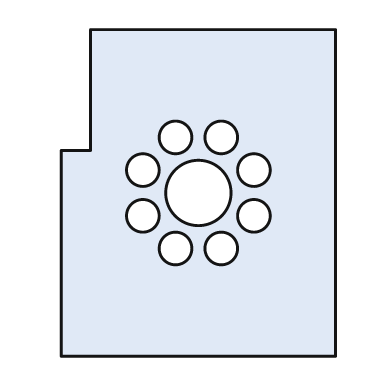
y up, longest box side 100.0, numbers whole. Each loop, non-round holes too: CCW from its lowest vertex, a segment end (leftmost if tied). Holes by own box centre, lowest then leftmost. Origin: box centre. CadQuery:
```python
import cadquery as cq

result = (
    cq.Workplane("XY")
    .moveTo(-42.0, -50.0)
    .lineTo(42.0, -50.0)
    .lineTo(42.0, 50.0)
    .lineTo(-33.0, 50.0)
    .lineTo(-33.0, 13.0)
    .lineTo(-42.0, 13.0)
    .close()
    .moveTo(-7.0, -17.0)
    .circle(5.0)
    .moveTo(7.0, -17.0)
    .circle(5.0)
    .moveTo(-17.0, -7.0)
    .circle(5.0)
    .moveTo(17.0, -7.0)
    .circle(5.0)
    .moveTo(0.0, 0.0)
    .circle(10.0)
    .moveTo(-17.0, 7.0)
    .circle(5.0)
    .moveTo(17.0, 7.0)
    .circle(5.0)
    .moveTo(-7.0, 17.0)
    .circle(5.0)
    .moveTo(7.0, 17.0)
    .circle(5.0)
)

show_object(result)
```